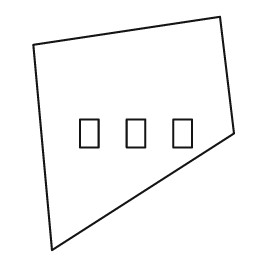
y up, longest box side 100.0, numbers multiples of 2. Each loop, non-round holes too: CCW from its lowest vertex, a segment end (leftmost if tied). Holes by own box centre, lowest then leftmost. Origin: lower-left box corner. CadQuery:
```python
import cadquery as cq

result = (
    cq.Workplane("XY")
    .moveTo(8.0, 0.0)
    .lineTo(86.0, 50.0)
    .lineTo(80.0, 100.0)
    .lineTo(0.0, 88.0)
    .close()
    .moveTo(20.0, 44.0)
    .lineTo(28.0, 44.0)
    .lineTo(28.0, 56.0)
    .lineTo(20.0, 56.0)
    .close()
    .moveTo(40.0, 44.0)
    .lineTo(48.0, 44.0)
    .lineTo(48.0, 56.0)
    .lineTo(40.0, 56.0)
    .close()
    .moveTo(60.0, 44.0)
    .lineTo(68.0, 44.0)
    .lineTo(68.0, 56.0)
    .lineTo(60.0, 56.0)
    .close()
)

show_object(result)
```